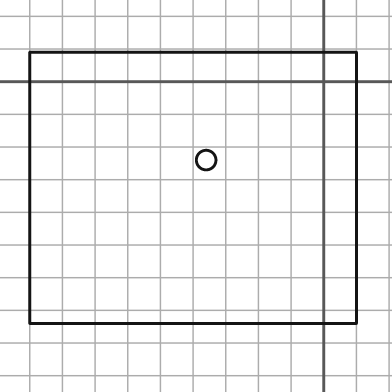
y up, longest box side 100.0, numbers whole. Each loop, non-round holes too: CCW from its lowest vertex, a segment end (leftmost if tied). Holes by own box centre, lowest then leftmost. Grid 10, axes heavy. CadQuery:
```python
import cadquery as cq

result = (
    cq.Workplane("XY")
    .moveTo(-90.0, -74.0)
    .lineTo(10.0, -74.0)
    .lineTo(10.0, 9.0)
    .lineTo(-90.0, 9.0)
    .close()
    .moveTo(-36.0, -24.0)
    .circle(3.0)
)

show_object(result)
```